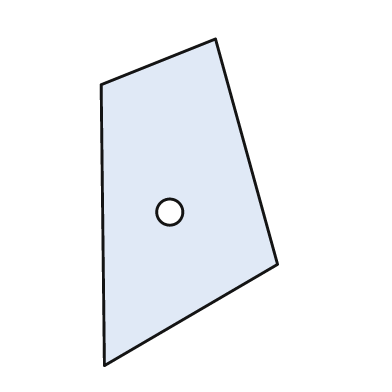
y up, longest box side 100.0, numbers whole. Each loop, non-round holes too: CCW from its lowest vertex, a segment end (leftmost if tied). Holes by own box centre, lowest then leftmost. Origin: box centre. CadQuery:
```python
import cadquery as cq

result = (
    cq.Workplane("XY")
    .moveTo(-26.0, -50.0)
    .lineTo(27.0, -19.0)
    .lineTo(8.0, 50.0)
    .lineTo(-27.0, 36.0)
    .close()
    .moveTo(-6.0, -3.0)
    .circle(4.0)
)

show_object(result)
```